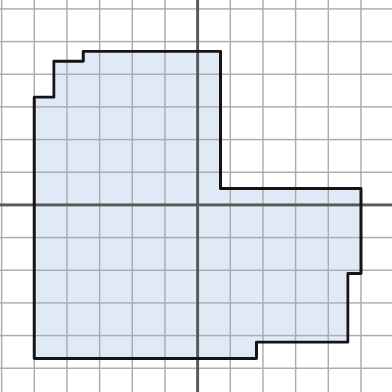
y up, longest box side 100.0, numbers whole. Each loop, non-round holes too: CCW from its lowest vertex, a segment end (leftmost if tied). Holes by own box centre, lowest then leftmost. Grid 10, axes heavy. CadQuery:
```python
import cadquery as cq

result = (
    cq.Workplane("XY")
    .moveTo(-50.0, -47.0)
    .lineTo(18.0, -47.0)
    .lineTo(18.0, -42.0)
    .lineTo(46.0, -42.0)
    .lineTo(46.0, -21.0)
    .lineTo(50.0, -21.0)
    .lineTo(50.0, 5.0)
    .lineTo(7.0, 5.0)
    .lineTo(7.0, 47.0)
    .lineTo(-35.0, 47.0)
    .lineTo(-35.0, 44.0)
    .lineTo(-44.0, 44.0)
    .lineTo(-44.0, 33.0)
    .lineTo(-50.0, 33.0)
    .close()
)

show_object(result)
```